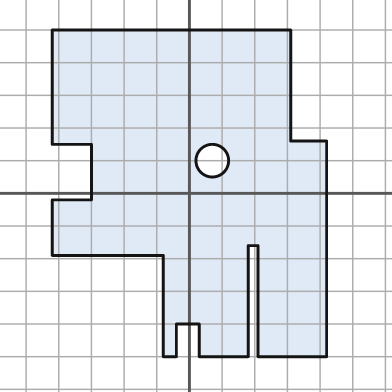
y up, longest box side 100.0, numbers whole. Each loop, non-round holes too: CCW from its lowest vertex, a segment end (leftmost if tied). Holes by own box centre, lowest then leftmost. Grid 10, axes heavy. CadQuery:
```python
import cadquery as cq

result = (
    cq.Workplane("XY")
    .moveTo(-8.0, -50.0)
    .lineTo(-4.0, -50.0)
    .lineTo(-4.0, -40.0)
    .lineTo(3.0, -40.0)
    .lineTo(3.0, -50.0)
    .lineTo(18.0, -50.0)
    .lineTo(18.0, -16.0)
    .lineTo(21.0, -16.0)
    .lineTo(21.0, -50.0)
    .lineTo(42.0, -50.0)
    .lineTo(42.0, 16.0)
    .lineTo(31.0, 16.0)
    .lineTo(31.0, 50.0)
    .lineTo(-42.0, 50.0)
    .lineTo(-42.0, 15.0)
    .lineTo(-30.0, 15.0)
    .lineTo(-30.0, -2.0)
    .lineTo(-42.0, -2.0)
    .lineTo(-42.0, -19.0)
    .lineTo(-8.0, -19.0)
    .close()
    .moveTo(7.0, 10.0)
    .circle(5.0)
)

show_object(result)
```